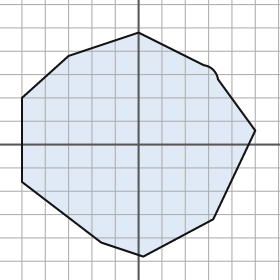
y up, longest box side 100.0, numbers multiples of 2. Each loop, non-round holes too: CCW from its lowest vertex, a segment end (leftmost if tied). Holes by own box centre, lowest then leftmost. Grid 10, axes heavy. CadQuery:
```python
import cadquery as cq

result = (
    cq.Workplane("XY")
    .moveTo(2.0, -48.0)
    .lineTo(32.0, -32.0)
    .lineTo(50.0, 6.0)
    .lineTo(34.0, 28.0)
    .threePointArc((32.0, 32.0), (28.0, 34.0))
    .lineTo(0.0, 48.0)
    .lineTo(-30.0, 38.0)
    .lineTo(-50.0, 20.0)
    .lineTo(-50.0, -16.0)
    .lineTo(-16.0, -42.0)
    .close()
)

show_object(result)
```